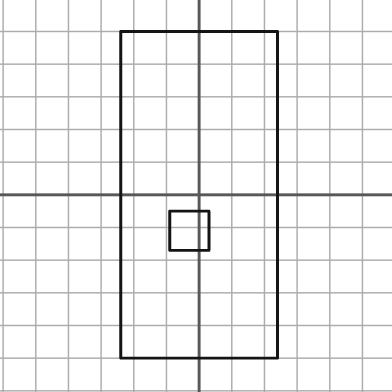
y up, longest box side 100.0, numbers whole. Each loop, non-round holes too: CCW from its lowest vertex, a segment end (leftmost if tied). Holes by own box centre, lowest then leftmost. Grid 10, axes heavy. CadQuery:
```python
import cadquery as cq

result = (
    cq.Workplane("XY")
    .moveTo(-24.0, -50.0)
    .lineTo(24.0, -50.0)
    .lineTo(24.0, 50.0)
    .lineTo(-24.0, 50.0)
    .close()
    .moveTo(-9.0, -17.0)
    .lineTo(3.0, -17.0)
    .lineTo(3.0, -5.0)
    .lineTo(-9.0, -5.0)
    .close()
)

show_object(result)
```